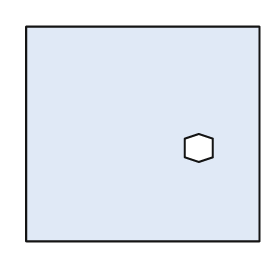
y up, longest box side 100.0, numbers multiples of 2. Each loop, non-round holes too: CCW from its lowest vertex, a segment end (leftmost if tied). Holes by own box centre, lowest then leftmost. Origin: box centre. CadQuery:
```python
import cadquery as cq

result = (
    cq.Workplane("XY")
    .moveTo(-50.0, -46.0)
    .lineTo(50.0, -46.0)
    .lineTo(50.0, 46.0)
    .lineTo(-50.0, 46.0)
    .close()
    .moveTo(24.0, -12.0)
    .lineTo(30.0, -10.0)
    .lineTo(30.0, -2.0)
    .lineTo(24.0, 0.0)
    .lineTo(18.0, -2.0)
    .lineTo(18.0, -10.0)
    .close()
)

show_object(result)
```